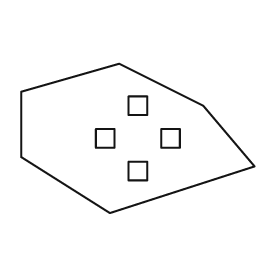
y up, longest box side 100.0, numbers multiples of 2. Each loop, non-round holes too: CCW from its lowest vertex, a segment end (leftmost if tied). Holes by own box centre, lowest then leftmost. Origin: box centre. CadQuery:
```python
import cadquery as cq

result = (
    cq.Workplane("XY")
    .moveTo(-12.0, -32.0)
    .lineTo(50.0, -12.0)
    .lineTo(28.0, 14.0)
    .lineTo(-8.0, 32.0)
    .lineTo(-50.0, 20.0)
    .lineTo(-50.0, -8.0)
    .close()
    .moveTo(-4.0, -18.0)
    .lineTo(4.0, -18.0)
    .lineTo(4.0, -10.0)
    .lineTo(-4.0, -10.0)
    .close()
    .moveTo(-18.0, -4.0)
    .lineTo(-10.0, -4.0)
    .lineTo(-10.0, 4.0)
    .lineTo(-18.0, 4.0)
    .close()
    .moveTo(10.0, -4.0)
    .lineTo(18.0, -4.0)
    .lineTo(18.0, 4.0)
    .lineTo(10.0, 4.0)
    .close()
    .moveTo(-4.0, 10.0)
    .lineTo(4.0, 10.0)
    .lineTo(4.0, 18.0)
    .lineTo(-4.0, 18.0)
    .close()
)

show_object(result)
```